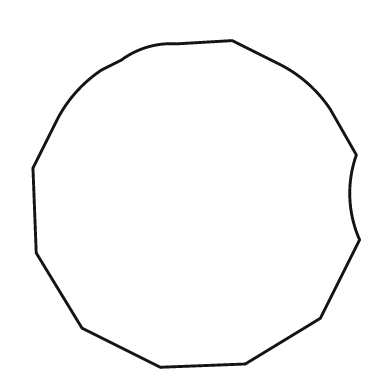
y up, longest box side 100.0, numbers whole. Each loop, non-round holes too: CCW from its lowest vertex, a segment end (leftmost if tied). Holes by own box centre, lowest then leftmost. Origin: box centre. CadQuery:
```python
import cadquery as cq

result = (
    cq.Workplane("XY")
    .moveTo(-11.0, -50.0)
    .lineTo(15.0, -49.0)
    .lineTo(38.0, -35.0)
    .lineTo(50.0, -11.0)
    .threePointArc((47.0, 2.0), (49.0, 15.0))
    .lineTo(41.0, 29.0)
    .threePointArc((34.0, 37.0), (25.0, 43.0))
    .lineTo(11.0, 50.0)
    .lineTo(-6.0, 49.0)
    .threePointArc((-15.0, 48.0), (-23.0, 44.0))
    .lineTo(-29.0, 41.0)
    .threePointArc((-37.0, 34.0), (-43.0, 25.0))
    .lineTo(-50.0, 11.0)
    .lineTo(-49.0, -15.0)
    .lineTo(-35.0, -38.0)
    .close()
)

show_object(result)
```